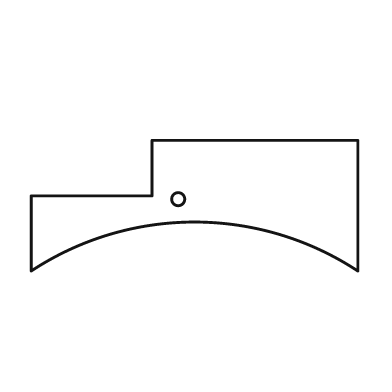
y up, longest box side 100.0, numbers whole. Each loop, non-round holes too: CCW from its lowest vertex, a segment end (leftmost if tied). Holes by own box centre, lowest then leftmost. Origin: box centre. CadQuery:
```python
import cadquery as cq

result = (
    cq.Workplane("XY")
    .moveTo(-50.0, -20.0)
    .threePointArc((0.0, -5.0), (50.0, -20.0))
    .lineTo(50.0, 20.0)
    .lineTo(-13.0, 20.0)
    .lineTo(-13.0, 3.0)
    .lineTo(-50.0, 3.0)
    .close()
    .moveTo(-5.0, 2.0)
    .circle(2.0)
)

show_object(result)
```